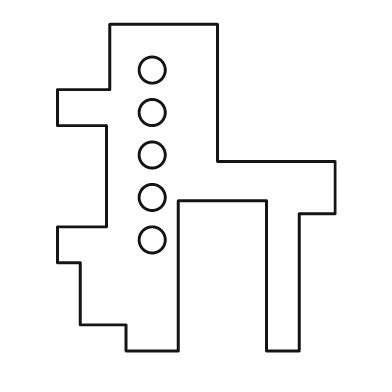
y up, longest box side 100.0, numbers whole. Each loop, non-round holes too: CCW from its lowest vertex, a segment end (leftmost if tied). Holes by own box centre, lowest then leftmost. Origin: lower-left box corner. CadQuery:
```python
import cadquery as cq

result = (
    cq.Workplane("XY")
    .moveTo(21.0, 0.0)
    .lineTo(37.0, 0.0)
    .lineTo(37.0, 46.0)
    .lineTo(64.0, 46.0)
    .lineTo(64.0, 0.0)
    .lineTo(74.0, 0.0)
    .lineTo(74.0, 42.0)
    .lineTo(85.0, 42.0)
    .lineTo(85.0, 58.0)
    .lineTo(49.0, 58.0)
    .lineTo(49.0, 100.0)
    .lineTo(16.0, 100.0)
    .lineTo(16.0, 80.0)
    .lineTo(0.0, 80.0)
    .lineTo(0.0, 69.0)
    .lineTo(15.0, 69.0)
    .lineTo(15.0, 38.0)
    .lineTo(0.0, 38.0)
    .lineTo(0.0, 27.0)
    .lineTo(7.0, 27.0)
    .lineTo(7.0, 8.0)
    .lineTo(21.0, 8.0)
    .close()
    .moveTo(29.0, 34.0)
    .circle(4.0)
    .moveTo(29.0, 47.0)
    .circle(4.0)
    .moveTo(29.0, 60.0)
    .circle(4.0)
    .moveTo(29.0, 73.0)
    .circle(4.0)
    .moveTo(29.0, 86.0)
    .circle(4.0)
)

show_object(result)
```